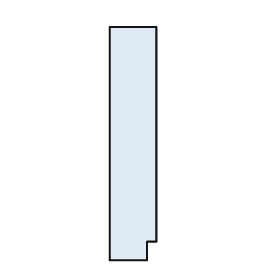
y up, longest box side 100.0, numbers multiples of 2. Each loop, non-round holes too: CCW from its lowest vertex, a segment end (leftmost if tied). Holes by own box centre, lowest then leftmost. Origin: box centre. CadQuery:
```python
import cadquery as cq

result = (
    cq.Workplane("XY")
    .moveTo(-10.0, -50.0)
    .lineTo(6.0, -50.0)
    .lineTo(6.0, -42.0)
    .lineTo(10.0, -42.0)
    .lineTo(10.0, 50.0)
    .lineTo(-10.0, 50.0)
    .close()
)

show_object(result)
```